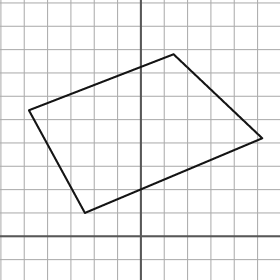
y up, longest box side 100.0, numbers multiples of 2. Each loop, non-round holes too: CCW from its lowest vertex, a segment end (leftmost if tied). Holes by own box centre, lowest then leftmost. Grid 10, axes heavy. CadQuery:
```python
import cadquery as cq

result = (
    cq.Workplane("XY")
    .moveTo(-24.0, 10.0)
    .lineTo(52.0, 42.0)
    .lineTo(14.0, 78.0)
    .lineTo(-48.0, 54.0)
    .close()
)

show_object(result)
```